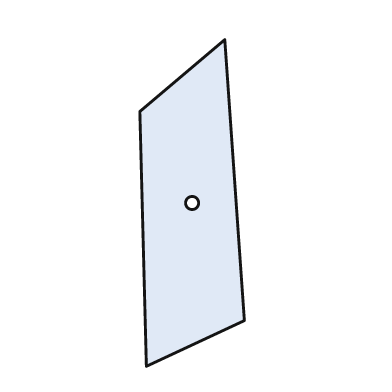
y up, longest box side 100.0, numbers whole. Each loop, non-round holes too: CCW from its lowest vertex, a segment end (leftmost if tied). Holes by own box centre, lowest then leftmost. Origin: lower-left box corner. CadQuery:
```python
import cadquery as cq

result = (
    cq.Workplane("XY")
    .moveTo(2.0, 0.0)
    .lineTo(32.0, 14.0)
    .lineTo(26.0, 100.0)
    .lineTo(0.0, 78.0)
    .close()
    .moveTo(16.0, 50.0)
    .circle(2.0)
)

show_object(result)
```